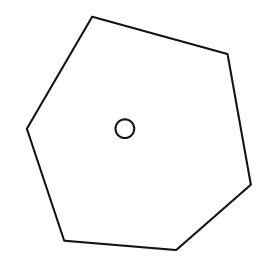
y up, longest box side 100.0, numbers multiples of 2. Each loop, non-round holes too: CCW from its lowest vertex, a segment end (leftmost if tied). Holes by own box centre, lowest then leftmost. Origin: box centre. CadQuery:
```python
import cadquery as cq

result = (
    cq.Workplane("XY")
    .moveTo(16.0, -50.0)
    .lineTo(48.0, -22.0)
    .lineTo(38.0, 34.0)
    .lineTo(-20.0, 50.0)
    .lineTo(-48.0, 2.0)
    .lineTo(-32.0, -46.0)
    .close()
    .moveTo(-6.0, 2.0)
    .circle(4.0)
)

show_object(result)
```